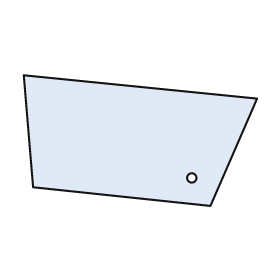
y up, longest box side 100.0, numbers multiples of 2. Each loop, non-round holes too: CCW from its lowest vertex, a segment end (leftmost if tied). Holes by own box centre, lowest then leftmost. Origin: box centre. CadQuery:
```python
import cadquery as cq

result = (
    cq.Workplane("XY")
    .moveTo(30.0, -28.0)
    .lineTo(50.0, 18.0)
    .lineTo(-50.0, 28.0)
    .lineTo(-46.0, -20.0)
    .close()
    .moveTo(22.0, -16.0)
    .circle(2.0)
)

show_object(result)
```